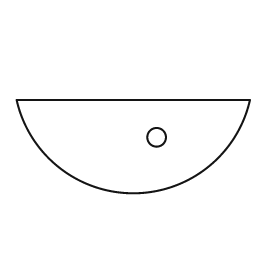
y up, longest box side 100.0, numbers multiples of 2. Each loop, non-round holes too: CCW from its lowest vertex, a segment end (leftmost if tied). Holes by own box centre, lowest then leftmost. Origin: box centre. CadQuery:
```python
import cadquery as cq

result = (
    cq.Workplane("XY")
    .moveTo(-50.0, 20.0)
    .threePointArc((0.0, -20.0), (50.0, 20.0))
    .close()
    .moveTo(10.0, 4.0)
    .circle(4.0)
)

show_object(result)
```